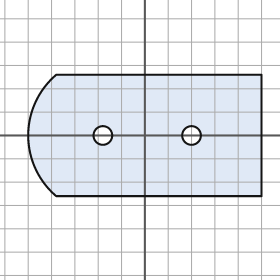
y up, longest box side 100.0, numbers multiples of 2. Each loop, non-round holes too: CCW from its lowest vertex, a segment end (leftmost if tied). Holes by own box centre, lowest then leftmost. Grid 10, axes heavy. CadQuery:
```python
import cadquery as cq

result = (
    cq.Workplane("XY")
    .moveTo(-38.0, -26.0)
    .lineTo(50.0, -26.0)
    .lineTo(50.0, 26.0)
    .lineTo(-38.0, 26.0)
    .threePointArc((-50.0, 0.0), (-38.0, -26.0))
    .close()
    .moveTo(-18.0, 0.0)
    .circle(4.0)
    .moveTo(20.0, 0.0)
    .circle(4.0)
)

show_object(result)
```